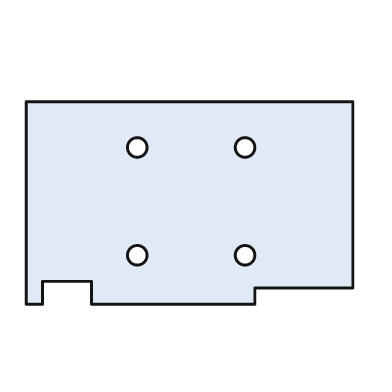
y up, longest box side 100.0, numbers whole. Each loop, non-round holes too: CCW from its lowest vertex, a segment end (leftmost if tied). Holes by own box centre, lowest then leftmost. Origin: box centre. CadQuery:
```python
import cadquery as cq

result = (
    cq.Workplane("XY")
    .moveTo(-50.0, -31.0)
    .lineTo(-45.0, -31.0)
    .lineTo(-45.0, -24.0)
    .lineTo(-30.0, -24.0)
    .lineTo(-30.0, -31.0)
    .lineTo(20.0, -31.0)
    .lineTo(20.0, -26.0)
    .lineTo(50.0, -26.0)
    .lineTo(50.0, 31.0)
    .lineTo(-50.0, 31.0)
    .close()
    .moveTo(-16.0, -16.0)
    .circle(3.0)
    .moveTo(17.0, -16.0)
    .circle(3.0)
    .moveTo(-16.0, 17.0)
    .circle(3.0)
    .moveTo(17.0, 17.0)
    .circle(3.0)
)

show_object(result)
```